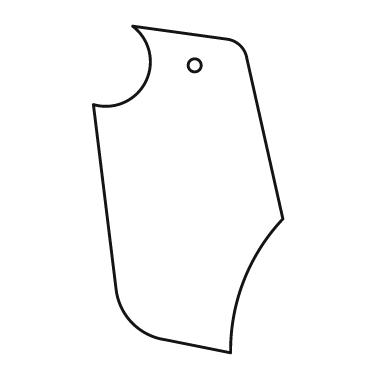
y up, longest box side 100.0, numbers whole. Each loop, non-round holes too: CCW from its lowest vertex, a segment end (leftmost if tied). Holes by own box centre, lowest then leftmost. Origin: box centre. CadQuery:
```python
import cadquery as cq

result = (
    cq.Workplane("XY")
    .moveTo(13.0, -50.0)
    .threePointArc((17.0, -28.0), (29.0, -9.0))
    .lineTo(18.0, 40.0)
    .threePointArc((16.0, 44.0), (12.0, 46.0))
    .lineTo(-17.0, 50.0)
    .threePointArc((-13.0, 33.0), (-29.0, 26.0))
    .lineTo(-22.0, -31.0)
    .threePointArc((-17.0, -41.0), (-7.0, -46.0))
    .close()
    .moveTo(2.0, 38.0)
    .circle(2.0)
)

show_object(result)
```